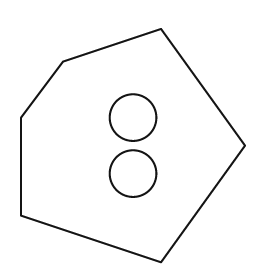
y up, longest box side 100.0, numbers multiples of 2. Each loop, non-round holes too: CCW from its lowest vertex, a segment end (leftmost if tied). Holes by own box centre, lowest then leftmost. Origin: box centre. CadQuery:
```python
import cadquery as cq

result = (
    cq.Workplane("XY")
    .moveTo(12.0, -50.0)
    .lineTo(48.0, 0.0)
    .lineTo(12.0, 50.0)
    .lineTo(-30.0, 36.0)
    .lineTo(-48.0, 12.0)
    .lineTo(-48.0, -30.0)
    .close()
    .moveTo(0.0, -12.0)
    .circle(10.0)
    .moveTo(0.0, 12.0)
    .circle(10.0)
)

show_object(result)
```